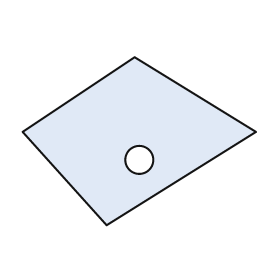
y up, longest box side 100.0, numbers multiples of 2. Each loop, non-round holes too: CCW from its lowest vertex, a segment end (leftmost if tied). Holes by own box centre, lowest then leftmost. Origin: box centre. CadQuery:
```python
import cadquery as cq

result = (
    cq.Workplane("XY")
    .moveTo(-14.0, -36.0)
    .lineTo(50.0, 4.0)
    .lineTo(-2.0, 36.0)
    .lineTo(-50.0, 4.0)
    .close()
    .moveTo(0.0, -8.0)
    .circle(6.0)
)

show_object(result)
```